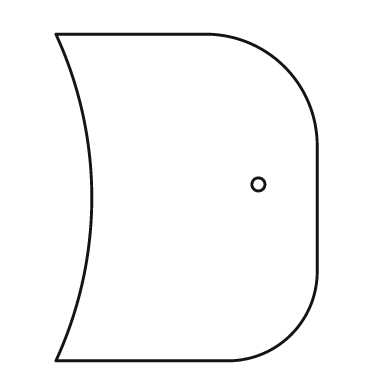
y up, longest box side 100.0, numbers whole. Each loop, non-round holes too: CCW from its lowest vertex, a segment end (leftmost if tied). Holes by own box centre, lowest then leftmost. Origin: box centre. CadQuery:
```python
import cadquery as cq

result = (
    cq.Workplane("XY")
    .moveTo(-40.0, -50.0)
    .lineTo(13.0, -50.0)
    .threePointArc((32.0, -42.0), (40.0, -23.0))
    .lineTo(40.0, 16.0)
    .threePointArc((30.0, 40.0), (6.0, 50.0))
    .lineTo(-40.0, 50.0)
    .threePointArc((-29.0, 0.0), (-40.0, -50.0))
    .close()
    .moveTo(22.0, 4.0)
    .circle(2.0)
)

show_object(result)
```